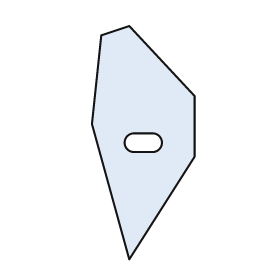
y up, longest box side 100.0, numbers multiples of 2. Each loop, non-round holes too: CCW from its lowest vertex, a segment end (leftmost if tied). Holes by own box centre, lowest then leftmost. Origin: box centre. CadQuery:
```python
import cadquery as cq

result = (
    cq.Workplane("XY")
    .moveTo(-6.0, -50.0)
    .lineTo(22.0, -6.0)
    .lineTo(22.0, 20.0)
    .lineTo(-6.0, 50.0)
    .lineTo(-18.0, 46.0)
    .lineTo(-22.0, 8.0)
    .close()
    .moveTo(-4.0, -4.0)
    .lineTo(4.0, -4.0)
    .threePointArc((8.0, 0.0), (4.0, 4.0))
    .lineTo(-4.0, 4.0)
    .threePointArc((-8.0, 0.0), (-4.0, -4.0))
    .close()
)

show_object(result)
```